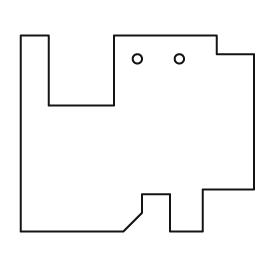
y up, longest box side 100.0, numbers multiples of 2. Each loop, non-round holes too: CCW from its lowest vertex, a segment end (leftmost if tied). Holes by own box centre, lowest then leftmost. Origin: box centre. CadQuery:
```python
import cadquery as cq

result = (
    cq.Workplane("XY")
    .moveTo(-50.0, -42.0)
    .lineTo(-6.0, -42.0)
    .lineTo(2.0, -34.0)
    .lineTo(2.0, -26.0)
    .lineTo(14.0, -26.0)
    .lineTo(14.0, -42.0)
    .lineTo(28.0, -42.0)
    .lineTo(28.0, -24.0)
    .lineTo(50.0, -24.0)
    .lineTo(50.0, 34.0)
    .lineTo(34.0, 34.0)
    .lineTo(34.0, 42.0)
    .lineTo(-10.0, 42.0)
    .lineTo(-10.0, 12.0)
    .lineTo(-38.0, 12.0)
    .lineTo(-38.0, 42.0)
    .lineTo(-50.0, 42.0)
    .close()
    .moveTo(0.0, 32.0)
    .circle(2.0)
    .moveTo(18.0, 32.0)
    .circle(2.0)
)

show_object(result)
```